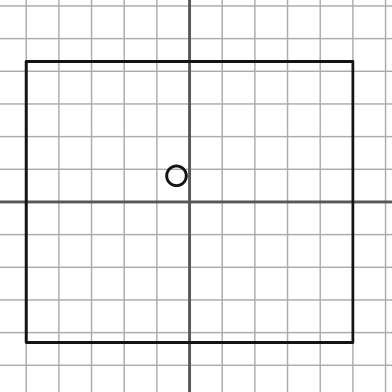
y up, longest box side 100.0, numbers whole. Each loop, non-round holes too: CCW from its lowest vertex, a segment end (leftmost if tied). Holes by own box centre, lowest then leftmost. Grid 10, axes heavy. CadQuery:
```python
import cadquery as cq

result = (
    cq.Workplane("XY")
    .moveTo(-50.0, -43.0)
    .lineTo(50.0, -43.0)
    .lineTo(50.0, 43.0)
    .lineTo(-50.0, 43.0)
    .close()
    .moveTo(-4.0, 8.0)
    .circle(3.0)
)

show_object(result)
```